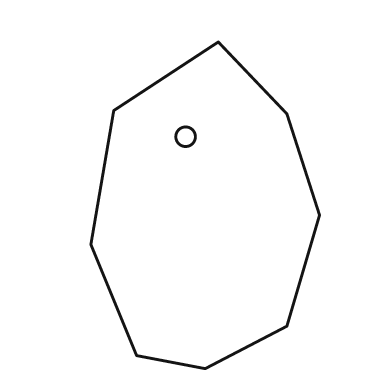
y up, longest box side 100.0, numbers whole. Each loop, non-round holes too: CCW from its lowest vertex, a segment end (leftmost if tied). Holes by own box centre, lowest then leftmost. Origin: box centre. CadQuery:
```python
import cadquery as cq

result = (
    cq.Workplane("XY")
    .moveTo(0.0, -50.0)
    .lineTo(25.0, -37.0)
    .lineTo(35.0, -3.0)
    .lineTo(25.0, 28.0)
    .lineTo(4.0, 50.0)
    .lineTo(-28.0, 29.0)
    .lineTo(-35.0, -12.0)
    .lineTo(-21.0, -46.0)
    .close()
    .moveTo(-6.0, 21.0)
    .circle(3.0)
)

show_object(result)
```